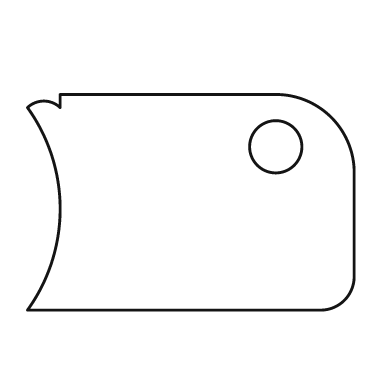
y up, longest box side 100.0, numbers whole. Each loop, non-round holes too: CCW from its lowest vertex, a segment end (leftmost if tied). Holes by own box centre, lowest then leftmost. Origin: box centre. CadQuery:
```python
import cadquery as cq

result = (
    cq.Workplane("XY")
    .moveTo(-50.0, -33.0)
    .lineTo(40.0, -33.0)
    .threePointArc((47.0, -30.0), (50.0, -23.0))
    .lineTo(50.0, 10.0)
    .threePointArc((43.0, 26.0), (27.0, 33.0))
    .lineTo(-40.0, 33.0)
    .lineTo(-40.0, 29.0)
    .threePointArc((-45.0, 31.0), (-50.0, 29.0))
    .threePointArc((-40.0, -2.0), (-50.0, -33.0))
    .close()
    .moveTo(26.0, 17.0)
    .circle(8.0)
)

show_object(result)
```